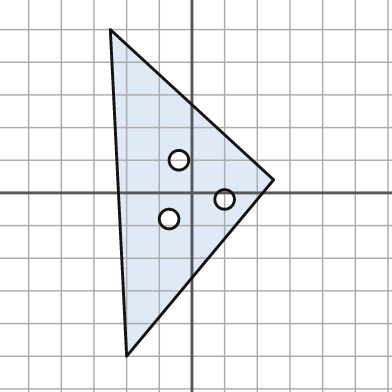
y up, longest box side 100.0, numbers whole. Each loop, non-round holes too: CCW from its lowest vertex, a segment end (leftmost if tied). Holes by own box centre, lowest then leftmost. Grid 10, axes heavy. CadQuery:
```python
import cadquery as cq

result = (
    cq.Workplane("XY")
    .moveTo(-20.0, -50.0)
    .lineTo(25.0, 4.0)
    .lineTo(-25.0, 50.0)
    .close()
    .moveTo(-7.0, -8.0)
    .circle(3.0)
    .moveTo(10.0, -2.0)
    .circle(3.0)
    .moveTo(-4.0, 10.0)
    .circle(3.0)
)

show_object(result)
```